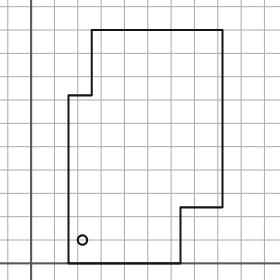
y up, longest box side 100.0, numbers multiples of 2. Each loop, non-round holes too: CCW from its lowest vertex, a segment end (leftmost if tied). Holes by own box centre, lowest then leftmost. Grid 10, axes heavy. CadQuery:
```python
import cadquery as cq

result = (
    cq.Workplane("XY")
    .moveTo(16.0, 0.0)
    .lineTo(64.0, 0.0)
    .lineTo(64.0, 24.0)
    .lineTo(82.0, 24.0)
    .lineTo(82.0, 100.0)
    .lineTo(26.0, 100.0)
    .lineTo(26.0, 72.0)
    .lineTo(16.0, 72.0)
    .close()
    .moveTo(22.0, 10.0)
    .circle(2.0)
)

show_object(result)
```